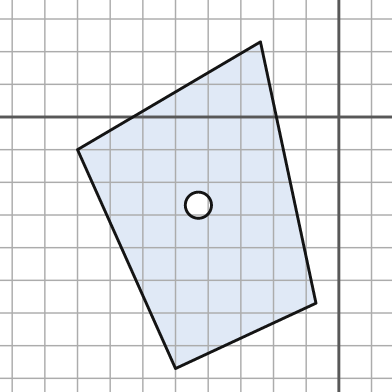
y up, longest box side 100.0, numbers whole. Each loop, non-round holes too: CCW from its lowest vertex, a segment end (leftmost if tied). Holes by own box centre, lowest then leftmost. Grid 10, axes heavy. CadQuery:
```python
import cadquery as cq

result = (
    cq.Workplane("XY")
    .moveTo(-50.0, -77.0)
    .lineTo(-7.0, -57.0)
    .lineTo(-24.0, 23.0)
    .lineTo(-80.0, -10.0)
    .close()
    .moveTo(-43.0, -27.0)
    .circle(4.0)
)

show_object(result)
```